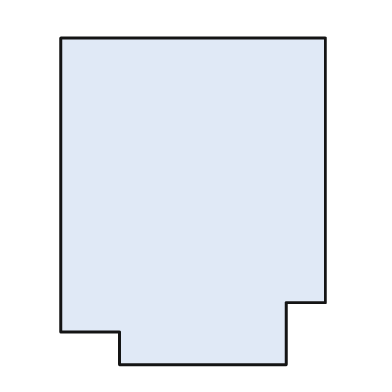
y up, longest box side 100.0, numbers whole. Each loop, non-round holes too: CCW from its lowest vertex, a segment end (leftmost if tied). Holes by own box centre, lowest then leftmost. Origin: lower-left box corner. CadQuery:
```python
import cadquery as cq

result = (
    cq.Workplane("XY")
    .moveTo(18.0, 0.0)
    .lineTo(69.0, 0.0)
    .lineTo(69.0, 19.0)
    .lineTo(81.0, 19.0)
    .lineTo(81.0, 100.0)
    .lineTo(0.0, 100.0)
    .lineTo(0.0, 10.0)
    .lineTo(18.0, 10.0)
    .close()
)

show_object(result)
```